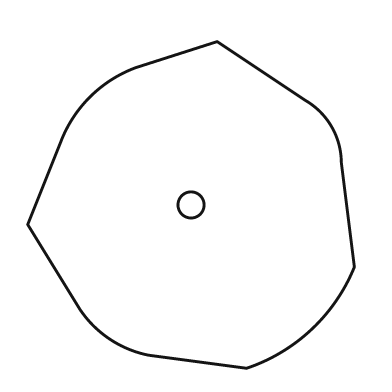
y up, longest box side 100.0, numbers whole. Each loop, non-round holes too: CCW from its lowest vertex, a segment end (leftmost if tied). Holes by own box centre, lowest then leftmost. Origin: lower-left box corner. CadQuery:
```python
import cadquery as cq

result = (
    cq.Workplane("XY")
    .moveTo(67.0, 0.0)
    .threePointArc((87.0, 12.0), (100.0, 31.0))
    .lineTo(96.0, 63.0)
    .threePointArc((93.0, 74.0), (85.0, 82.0))
    .lineTo(58.0, 100.0)
    .lineTo(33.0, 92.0)
    .threePointArc((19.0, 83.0), (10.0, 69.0))
    .lineTo(0.0, 44.0)
    .lineTo(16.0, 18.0)
    .threePointArc((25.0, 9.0), (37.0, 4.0))
    .close()
    .moveTo(50.0, 50.0)
    .circle(4.0)
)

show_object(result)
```